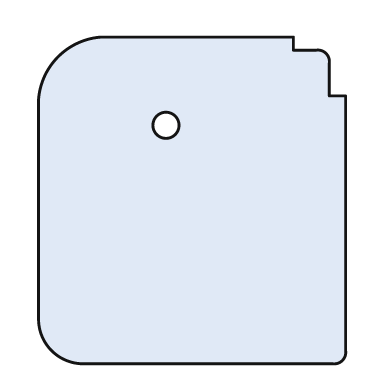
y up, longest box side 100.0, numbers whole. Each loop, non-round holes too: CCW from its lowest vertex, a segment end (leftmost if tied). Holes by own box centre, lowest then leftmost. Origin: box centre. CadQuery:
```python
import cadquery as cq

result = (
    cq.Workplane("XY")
    .moveTo(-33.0, -50.0)
    .lineTo(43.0, -50.0)
    .threePointArc((46.0, -49.0), (47.0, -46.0))
    .lineTo(47.0, 32.0)
    .lineTo(42.0, 32.0)
    .lineTo(42.0, 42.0)
    .threePointArc((41.0, 45.0), (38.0, 46.0))
    .lineTo(31.0, 46.0)
    .lineTo(31.0, 50.0)
    .lineTo(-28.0, 50.0)
    .threePointArc((-41.0, 44.0), (-47.0, 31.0))
    .lineTo(-47.0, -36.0)
    .threePointArc((-43.0, -46.0), (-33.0, -50.0))
    .close()
    .moveTo(-8.0, 23.0)
    .circle(4.0)
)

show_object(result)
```